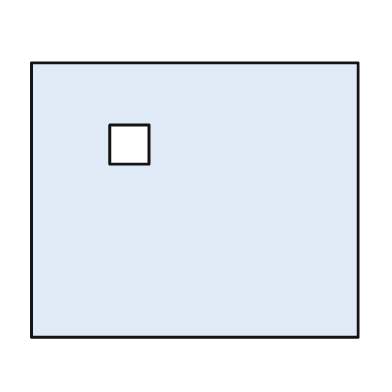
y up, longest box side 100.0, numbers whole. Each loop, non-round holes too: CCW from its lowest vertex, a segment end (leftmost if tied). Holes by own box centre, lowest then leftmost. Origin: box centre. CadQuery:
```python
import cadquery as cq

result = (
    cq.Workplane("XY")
    .moveTo(-50.0, -42.0)
    .lineTo(50.0, -42.0)
    .lineTo(50.0, 42.0)
    .lineTo(-50.0, 42.0)
    .close()
    .moveTo(-26.0, 11.0)
    .lineTo(-14.0, 11.0)
    .lineTo(-14.0, 23.0)
    .lineTo(-26.0, 23.0)
    .close()
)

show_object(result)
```